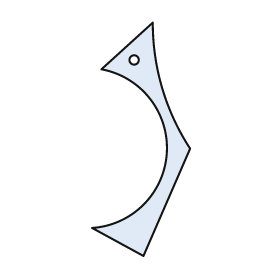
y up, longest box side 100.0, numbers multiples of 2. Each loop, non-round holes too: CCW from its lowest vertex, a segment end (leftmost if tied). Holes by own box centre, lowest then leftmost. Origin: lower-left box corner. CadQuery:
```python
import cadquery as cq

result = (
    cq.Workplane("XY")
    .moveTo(22.0, 0.0)
    .lineTo(42.0, 46.0)
    .threePointArc((30.0, 72.0), (26.0, 100.0))
    .lineTo(4.0, 80.0)
    .threePointArc((32.0, 44.0), (0.0, 12.0))
    .close()
    .moveTo(18.0, 84.0)
    .circle(2.0)
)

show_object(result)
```